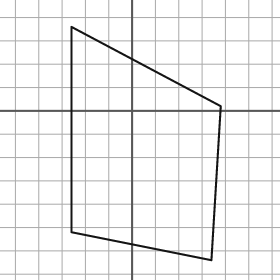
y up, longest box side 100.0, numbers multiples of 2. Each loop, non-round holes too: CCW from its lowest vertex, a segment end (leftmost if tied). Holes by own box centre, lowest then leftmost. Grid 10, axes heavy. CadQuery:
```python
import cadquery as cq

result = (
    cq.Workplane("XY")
    .moveTo(34.0, -64.0)
    .lineTo(38.0, 2.0)
    .lineTo(-26.0, 36.0)
    .lineTo(-26.0, -52.0)
    .close()
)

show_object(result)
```